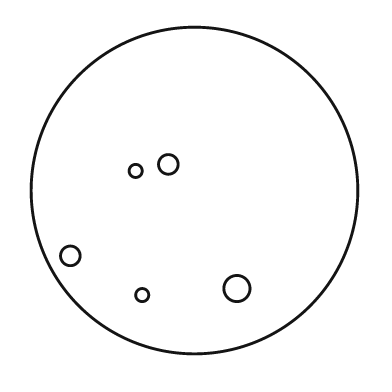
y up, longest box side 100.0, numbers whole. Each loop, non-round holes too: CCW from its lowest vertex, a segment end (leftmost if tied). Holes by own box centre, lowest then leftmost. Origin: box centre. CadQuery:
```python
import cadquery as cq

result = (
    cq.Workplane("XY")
    .moveTo(0.0, 0.0)
    .circle(50.0)
    .moveTo(-16.0, -32.0)
    .circle(2.0)
    .moveTo(13.0, -30.0)
    .circle(4.0)
    .moveTo(-38.0, -20.0)
    .circle(3.0)
    .moveTo(-18.0, 6.0)
    .circle(2.0)
    .moveTo(-8.0, 8.0)
    .circle(3.0)
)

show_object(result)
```